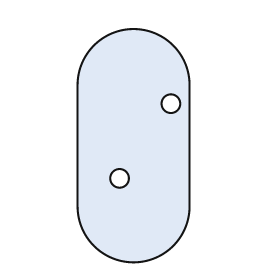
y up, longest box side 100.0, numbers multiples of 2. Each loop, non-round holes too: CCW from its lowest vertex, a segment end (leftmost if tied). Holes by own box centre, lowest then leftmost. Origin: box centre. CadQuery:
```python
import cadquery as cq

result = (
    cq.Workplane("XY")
    .moveTo(-24.0, -26.0)
    .threePointArc((0.0, -50.0), (24.0, -26.0))
    .lineTo(24.0, 26.0)
    .threePointArc((0.0, 50.0), (-24.0, 26.0))
    .close()
    .moveTo(-6.0, -14.0)
    .circle(4.0)
    .moveTo(16.0, 18.0)
    .circle(4.0)
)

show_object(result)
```